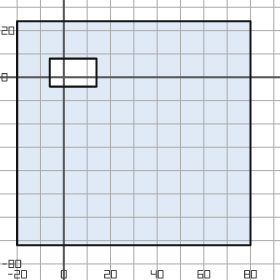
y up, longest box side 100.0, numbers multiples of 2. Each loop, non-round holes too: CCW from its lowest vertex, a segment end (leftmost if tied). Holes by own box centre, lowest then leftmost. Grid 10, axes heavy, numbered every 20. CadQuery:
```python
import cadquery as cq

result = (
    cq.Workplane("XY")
    .moveTo(-20.0, -72.0)
    .lineTo(80.0, -72.0)
    .lineTo(80.0, 24.0)
    .lineTo(-20.0, 24.0)
    .close()
    .moveTo(-6.0, -4.0)
    .lineTo(14.0, -4.0)
    .lineTo(14.0, 8.0)
    .lineTo(-6.0, 8.0)
    .close()
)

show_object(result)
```